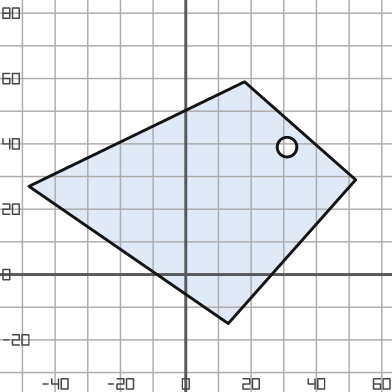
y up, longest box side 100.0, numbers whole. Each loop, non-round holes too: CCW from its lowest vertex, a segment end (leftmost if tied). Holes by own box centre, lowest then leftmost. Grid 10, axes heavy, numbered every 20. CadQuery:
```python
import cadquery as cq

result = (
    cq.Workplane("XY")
    .moveTo(13.0, -15.0)
    .lineTo(52.0, 29.0)
    .lineTo(18.0, 59.0)
    .lineTo(-48.0, 27.0)
    .close()
    .moveTo(31.0, 39.0)
    .circle(3.0)
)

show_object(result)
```